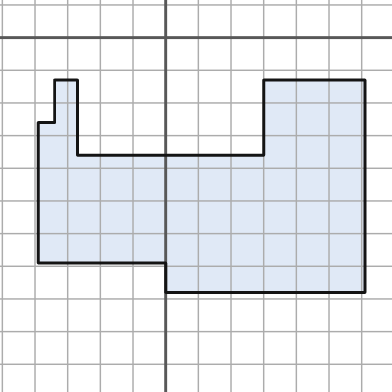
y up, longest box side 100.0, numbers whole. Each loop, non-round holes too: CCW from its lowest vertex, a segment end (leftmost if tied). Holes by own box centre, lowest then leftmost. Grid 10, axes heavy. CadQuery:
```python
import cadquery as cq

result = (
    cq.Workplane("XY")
    .moveTo(0.0, -78.0)
    .lineTo(61.0, -78.0)
    .lineTo(61.0, -13.0)
    .lineTo(30.0, -13.0)
    .lineTo(30.0, -36.0)
    .lineTo(-27.0, -36.0)
    .lineTo(-27.0, -13.0)
    .lineTo(-34.0, -13.0)
    .lineTo(-34.0, -26.0)
    .lineTo(-39.0, -26.0)
    .lineTo(-39.0, -69.0)
    .lineTo(0.0, -69.0)
    .close()
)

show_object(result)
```